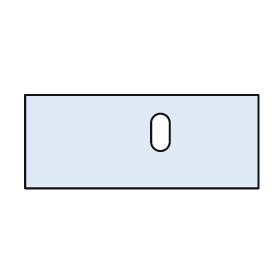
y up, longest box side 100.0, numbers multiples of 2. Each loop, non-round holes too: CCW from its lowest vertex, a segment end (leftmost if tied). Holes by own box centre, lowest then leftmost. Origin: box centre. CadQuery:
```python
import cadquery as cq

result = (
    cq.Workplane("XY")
    .moveTo(-50.0, -20.0)
    .lineTo(50.0, -20.0)
    .lineTo(50.0, 20.0)
    .lineTo(-50.0, 20.0)
    .close()
    .moveTo(4.0, 0.0)
    .threePointArc((8.0, -4.0), (12.0, 0.0))
    .lineTo(12.0, 8.0)
    .threePointArc((8.0, 12.0), (4.0, 8.0))
    .close()
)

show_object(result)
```